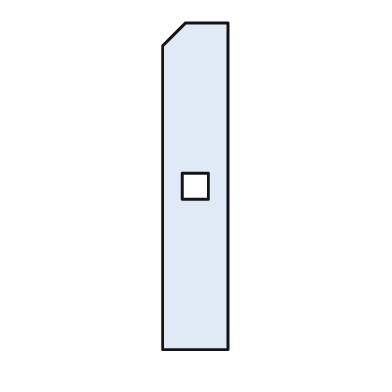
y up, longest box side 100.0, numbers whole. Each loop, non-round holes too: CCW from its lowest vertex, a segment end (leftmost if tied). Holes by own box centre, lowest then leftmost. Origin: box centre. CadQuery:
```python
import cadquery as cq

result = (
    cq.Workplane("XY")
    .moveTo(-10.0, -50.0)
    .lineTo(10.0, -50.0)
    .lineTo(10.0, 50.0)
    .lineTo(-3.0, 50.0)
    .lineTo(-10.0, 43.0)
    .close()
    .moveTo(-4.0, -4.0)
    .lineTo(4.0, -4.0)
    .lineTo(4.0, 4.0)
    .lineTo(-4.0, 4.0)
    .close()
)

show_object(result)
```